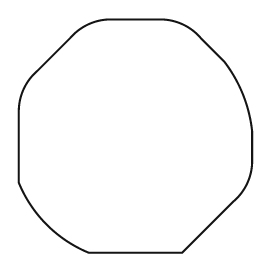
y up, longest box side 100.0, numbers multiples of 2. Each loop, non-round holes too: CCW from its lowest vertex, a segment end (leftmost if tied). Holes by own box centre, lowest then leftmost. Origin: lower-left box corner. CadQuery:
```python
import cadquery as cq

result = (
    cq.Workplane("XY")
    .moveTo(30.0, 0.0)
    .lineTo(70.0, 0.0)
    .lineTo(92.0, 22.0)
    .threePointArc((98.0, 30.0), (100.0, 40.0))
    .lineTo(100.0, 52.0)
    .threePointArc((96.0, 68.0), (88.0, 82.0))
    .lineTo(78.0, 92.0)
    .threePointArc((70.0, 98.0), (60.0, 100.0))
    .lineTo(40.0, 100.0)
    .threePointArc((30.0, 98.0), (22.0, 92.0))
    .lineTo(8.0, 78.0)
    .threePointArc((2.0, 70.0), (0.0, 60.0))
    .lineTo(0.0, 30.0)
    .threePointArc((12.0, 12.0), (30.0, 0.0))
    .close()
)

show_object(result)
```